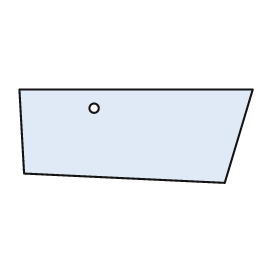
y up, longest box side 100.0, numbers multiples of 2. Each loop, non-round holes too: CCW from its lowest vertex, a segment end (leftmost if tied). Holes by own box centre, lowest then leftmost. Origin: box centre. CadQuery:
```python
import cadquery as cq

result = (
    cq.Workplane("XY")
    .moveTo(38.0, -20.0)
    .lineTo(50.0, 20.0)
    .lineTo(-50.0, 20.0)
    .lineTo(-48.0, -16.0)
    .close()
    .moveTo(-18.0, 12.0)
    .circle(2.0)
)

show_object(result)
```